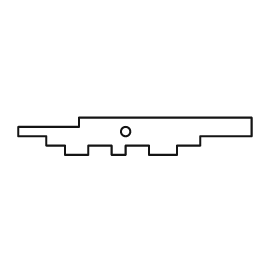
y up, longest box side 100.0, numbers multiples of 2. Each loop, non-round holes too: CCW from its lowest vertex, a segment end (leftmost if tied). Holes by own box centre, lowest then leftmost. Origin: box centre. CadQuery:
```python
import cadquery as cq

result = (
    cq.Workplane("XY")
    .moveTo(-30.0, -8.0)
    .lineTo(-20.0, -8.0)
    .lineTo(-20.0, -4.0)
    .lineTo(-10.0, -4.0)
    .lineTo(-10.0, -8.0)
    .lineTo(-4.0, -8.0)
    .lineTo(-4.0, -4.0)
    .lineTo(6.0, -4.0)
    .lineTo(6.0, -8.0)
    .lineTo(18.0, -8.0)
    .lineTo(18.0, -4.0)
    .lineTo(28.0, -4.0)
    .lineTo(28.0, 0.0)
    .lineTo(50.0, 0.0)
    .lineTo(50.0, 8.0)
    .lineTo(-24.0, 8.0)
    .lineTo(-24.0, 4.0)
    .lineTo(-50.0, 4.0)
    .lineTo(-50.0, 0.0)
    .lineTo(-38.0, 0.0)
    .lineTo(-38.0, -4.0)
    .lineTo(-30.0, -4.0)
    .close()
    .moveTo(-4.0, 2.0)
    .circle(2.0)
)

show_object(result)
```